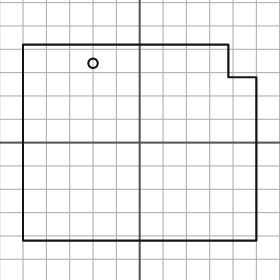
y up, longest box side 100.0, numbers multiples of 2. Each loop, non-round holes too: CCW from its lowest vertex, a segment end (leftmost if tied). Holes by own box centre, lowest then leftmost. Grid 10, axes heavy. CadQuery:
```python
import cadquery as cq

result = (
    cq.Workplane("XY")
    .moveTo(-50.0, -42.0)
    .lineTo(50.0, -42.0)
    .lineTo(50.0, 28.0)
    .lineTo(38.0, 28.0)
    .lineTo(38.0, 42.0)
    .lineTo(-50.0, 42.0)
    .close()
    .moveTo(-20.0, 34.0)
    .circle(2.0)
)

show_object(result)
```